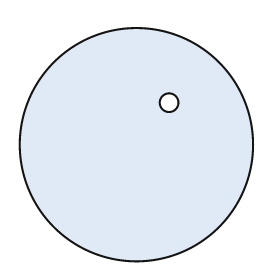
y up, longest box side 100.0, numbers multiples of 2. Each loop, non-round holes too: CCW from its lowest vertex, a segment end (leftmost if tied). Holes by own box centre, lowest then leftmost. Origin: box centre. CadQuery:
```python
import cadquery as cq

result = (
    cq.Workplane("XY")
    .moveTo(0.0, 0.0)
    .circle(50.0)
    .moveTo(14.0, 18.0)
    .circle(4.0)
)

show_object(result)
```